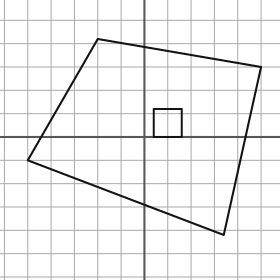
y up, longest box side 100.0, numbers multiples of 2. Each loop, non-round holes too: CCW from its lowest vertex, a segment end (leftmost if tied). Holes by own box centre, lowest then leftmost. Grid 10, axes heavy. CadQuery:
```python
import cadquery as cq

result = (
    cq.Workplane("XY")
    .moveTo(34.0, -42.0)
    .lineTo(50.0, 30.0)
    .lineTo(-20.0, 42.0)
    .lineTo(-50.0, -10.0)
    .close()
    .moveTo(4.0, 0.0)
    .lineTo(16.0, 0.0)
    .lineTo(16.0, 12.0)
    .lineTo(4.0, 12.0)
    .close()
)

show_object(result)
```